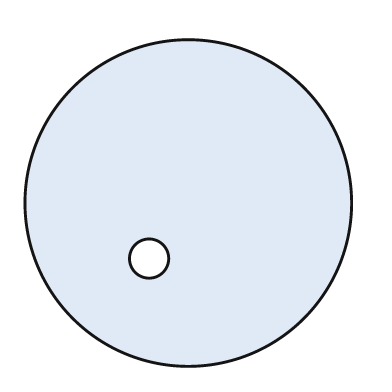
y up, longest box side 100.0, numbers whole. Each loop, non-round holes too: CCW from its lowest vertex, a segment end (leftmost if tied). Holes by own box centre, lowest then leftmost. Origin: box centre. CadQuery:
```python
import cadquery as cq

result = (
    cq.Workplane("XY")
    .moveTo(0.0, 0.0)
    .circle(50.0)
    .moveTo(-12.0, -17.0)
    .circle(6.0)
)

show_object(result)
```